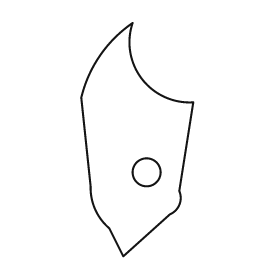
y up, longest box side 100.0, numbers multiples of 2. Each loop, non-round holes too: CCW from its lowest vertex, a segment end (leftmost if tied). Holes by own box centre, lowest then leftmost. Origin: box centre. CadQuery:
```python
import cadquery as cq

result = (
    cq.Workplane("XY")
    .moveTo(-6.0, -50.0)
    .lineTo(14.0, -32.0)
    .threePointArc((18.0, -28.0), (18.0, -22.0))
    .lineTo(24.0, 16.0)
    .threePointArc((2.0, 26.0), (-2.0, 50.0))
    .threePointArc((-16.0, 36.0), (-24.0, 18.0))
    .lineTo(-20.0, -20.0)
    .threePointArc((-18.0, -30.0), (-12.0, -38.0))
    .close()
    .moveTo(4.0, -14.0)
    .circle(6.0)
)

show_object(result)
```